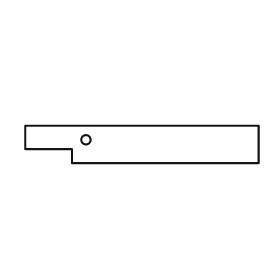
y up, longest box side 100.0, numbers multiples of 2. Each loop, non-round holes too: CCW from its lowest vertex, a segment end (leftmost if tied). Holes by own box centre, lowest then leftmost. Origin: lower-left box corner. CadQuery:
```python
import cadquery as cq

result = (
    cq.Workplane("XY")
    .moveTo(20.0, 0.0)
    .lineTo(100.0, 0.0)
    .lineTo(100.0, 16.0)
    .lineTo(0.0, 16.0)
    .lineTo(0.0, 6.0)
    .lineTo(20.0, 6.0)
    .close()
    .moveTo(26.0, 10.0)
    .circle(2.0)
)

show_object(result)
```